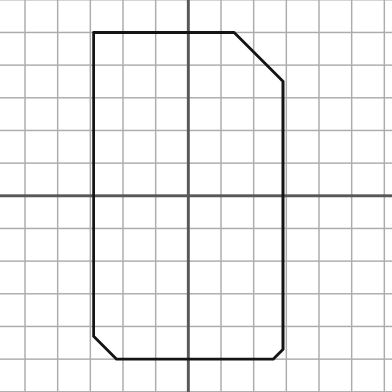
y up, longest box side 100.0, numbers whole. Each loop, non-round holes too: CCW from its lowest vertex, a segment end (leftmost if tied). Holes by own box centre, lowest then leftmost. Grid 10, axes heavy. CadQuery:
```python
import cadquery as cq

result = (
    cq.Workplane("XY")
    .moveTo(-22.0, -50.0)
    .lineTo(26.0, -50.0)
    .lineTo(29.0, -47.0)
    .lineTo(29.0, 35.0)
    .lineTo(14.0, 50.0)
    .lineTo(-29.0, 50.0)
    .lineTo(-29.0, -43.0)
    .close()
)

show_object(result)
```